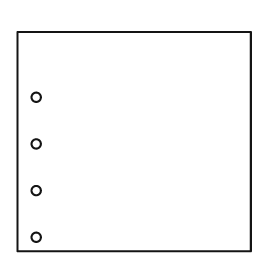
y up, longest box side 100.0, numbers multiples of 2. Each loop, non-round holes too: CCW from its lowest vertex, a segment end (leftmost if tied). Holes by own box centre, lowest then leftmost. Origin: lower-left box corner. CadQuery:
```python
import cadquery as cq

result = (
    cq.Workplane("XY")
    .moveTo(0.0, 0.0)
    .lineTo(100.0, 0.0)
    .lineTo(100.0, 94.0)
    .lineTo(0.0, 94.0)
    .close()
    .moveTo(8.0, 6.0)
    .circle(2.0)
    .moveTo(8.0, 26.0)
    .circle(2.0)
    .moveTo(8.0, 46.0)
    .circle(2.0)
    .moveTo(8.0, 66.0)
    .circle(2.0)
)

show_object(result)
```